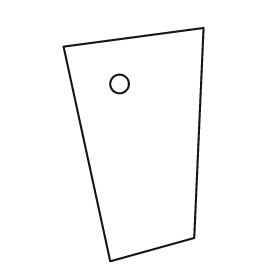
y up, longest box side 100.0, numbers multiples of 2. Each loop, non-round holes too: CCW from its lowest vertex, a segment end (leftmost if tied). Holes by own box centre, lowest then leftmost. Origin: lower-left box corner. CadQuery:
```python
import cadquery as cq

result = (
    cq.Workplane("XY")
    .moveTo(20.0, 0.0)
    .lineTo(56.0, 10.0)
    .lineTo(60.0, 100.0)
    .lineTo(0.0, 92.0)
    .close()
    .moveTo(24.0, 76.0)
    .circle(4.0)
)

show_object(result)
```